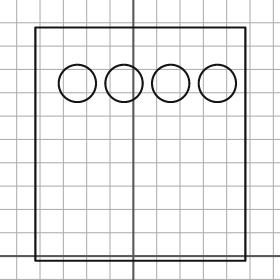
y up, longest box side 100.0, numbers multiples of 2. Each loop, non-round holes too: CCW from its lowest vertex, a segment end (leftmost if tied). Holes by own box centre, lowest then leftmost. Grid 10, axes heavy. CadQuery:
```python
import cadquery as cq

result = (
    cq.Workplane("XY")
    .moveTo(-42.0, -2.0)
    .lineTo(48.0, -2.0)
    .lineTo(48.0, 98.0)
    .lineTo(-42.0, 98.0)
    .close()
    .moveTo(-24.0, 74.0)
    .circle(8.0)
    .moveTo(-4.0, 74.0)
    .circle(8.0)
    .moveTo(16.0, 74.0)
    .circle(8.0)
    .moveTo(36.0, 74.0)
    .circle(8.0)
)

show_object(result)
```